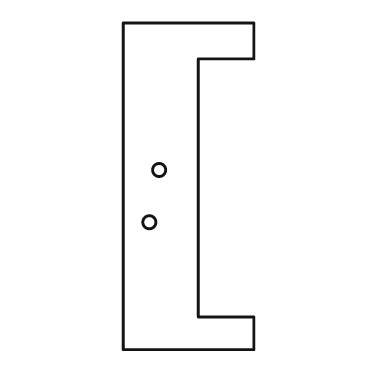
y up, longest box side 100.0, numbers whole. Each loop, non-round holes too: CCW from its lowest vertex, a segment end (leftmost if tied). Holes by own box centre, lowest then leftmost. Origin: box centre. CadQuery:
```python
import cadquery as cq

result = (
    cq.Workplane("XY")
    .moveTo(-20.0, -50.0)
    .lineTo(20.0, -50.0)
    .lineTo(20.0, -40.0)
    .lineTo(3.0, -40.0)
    .lineTo(3.0, 39.0)
    .lineTo(20.0, 39.0)
    .lineTo(20.0, 50.0)
    .lineTo(-20.0, 50.0)
    .close()
    .moveTo(-12.0, -11.0)
    .circle(2.0)
    .moveTo(-9.0, 5.0)
    .circle(2.0)
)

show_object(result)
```